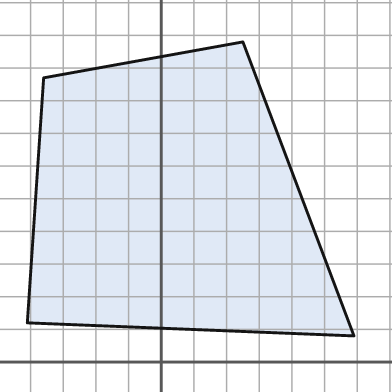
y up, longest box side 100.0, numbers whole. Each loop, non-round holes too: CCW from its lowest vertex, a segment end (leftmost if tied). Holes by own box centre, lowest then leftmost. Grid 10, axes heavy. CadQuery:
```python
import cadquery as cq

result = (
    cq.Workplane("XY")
    .moveTo(59.0, 8.0)
    .lineTo(25.0, 98.0)
    .lineTo(-36.0, 87.0)
    .lineTo(-41.0, 12.0)
    .close()
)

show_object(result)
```